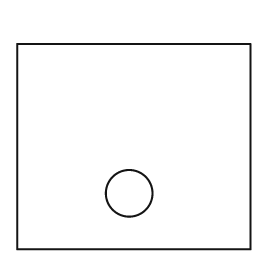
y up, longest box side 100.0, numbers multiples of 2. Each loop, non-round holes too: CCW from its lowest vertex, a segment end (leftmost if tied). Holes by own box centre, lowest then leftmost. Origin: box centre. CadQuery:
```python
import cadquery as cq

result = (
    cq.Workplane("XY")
    .moveTo(-50.0, -44.0)
    .lineTo(50.0, -44.0)
    .lineTo(50.0, 44.0)
    .lineTo(-50.0, 44.0)
    .close()
    .moveTo(-2.0, -20.0)
    .circle(10.0)
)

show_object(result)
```